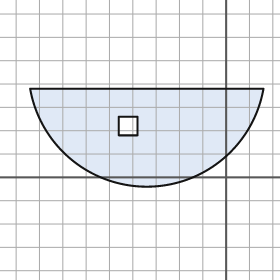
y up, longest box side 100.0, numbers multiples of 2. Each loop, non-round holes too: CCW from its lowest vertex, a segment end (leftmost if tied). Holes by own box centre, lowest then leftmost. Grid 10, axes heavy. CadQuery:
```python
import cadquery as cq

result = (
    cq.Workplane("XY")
    .moveTo(-84.0, 38.0)
    .threePointArc((-34.0, -4.0), (16.0, 38.0))
    .close()
    .moveTo(-46.0, 18.0)
    .lineTo(-38.0, 18.0)
    .lineTo(-38.0, 26.0)
    .lineTo(-46.0, 26.0)
    .close()
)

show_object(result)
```